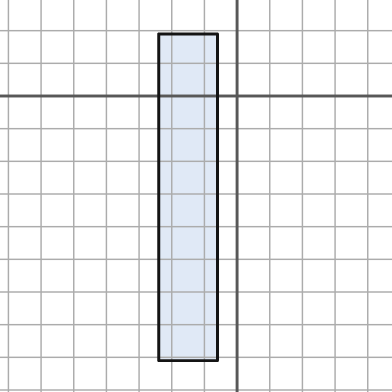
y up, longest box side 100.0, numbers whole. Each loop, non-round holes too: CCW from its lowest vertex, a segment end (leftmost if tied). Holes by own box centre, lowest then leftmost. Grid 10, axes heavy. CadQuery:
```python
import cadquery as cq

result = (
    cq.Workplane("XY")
    .moveTo(-24.0, -81.0)
    .lineTo(-6.0, -81.0)
    .lineTo(-6.0, 19.0)
    .lineTo(-24.0, 19.0)
    .close()
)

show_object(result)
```